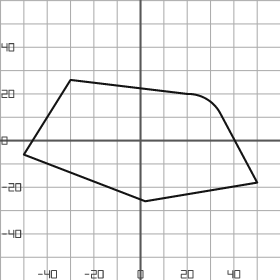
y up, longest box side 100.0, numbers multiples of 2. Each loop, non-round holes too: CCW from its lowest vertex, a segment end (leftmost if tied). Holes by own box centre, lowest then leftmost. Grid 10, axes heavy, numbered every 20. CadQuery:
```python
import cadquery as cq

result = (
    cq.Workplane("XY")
    .moveTo(2.0, -26.0)
    .lineTo(50.0, -18.0)
    .lineTo(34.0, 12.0)
    .threePointArc((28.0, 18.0), (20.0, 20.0))
    .lineTo(-30.0, 26.0)
    .lineTo(-50.0, -6.0)
    .close()
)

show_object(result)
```